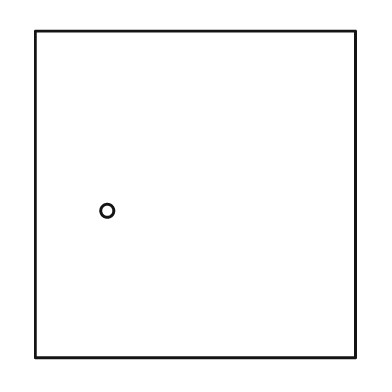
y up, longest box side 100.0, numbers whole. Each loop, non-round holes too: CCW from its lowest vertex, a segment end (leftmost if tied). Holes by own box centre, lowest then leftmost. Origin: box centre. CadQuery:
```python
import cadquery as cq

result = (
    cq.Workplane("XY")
    .moveTo(-49.0, -50.0)
    .lineTo(49.0, -50.0)
    .lineTo(49.0, 50.0)
    .lineTo(-49.0, 50.0)
    .close()
    .moveTo(-27.0, -5.0)
    .circle(2.0)
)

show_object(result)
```